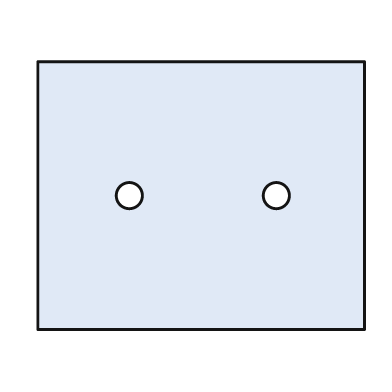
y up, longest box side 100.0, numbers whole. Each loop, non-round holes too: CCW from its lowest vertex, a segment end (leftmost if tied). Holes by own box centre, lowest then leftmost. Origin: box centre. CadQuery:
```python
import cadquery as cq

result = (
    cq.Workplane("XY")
    .moveTo(-50.0, -41.0)
    .lineTo(50.0, -41.0)
    .lineTo(50.0, 41.0)
    .lineTo(-50.0, 41.0)
    .close()
    .moveTo(-22.0, 0.0)
    .circle(4.0)
    .moveTo(23.0, 0.0)
    .circle(4.0)
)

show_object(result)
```